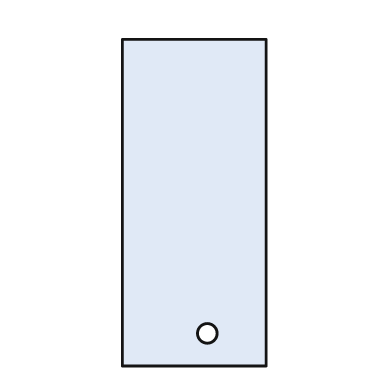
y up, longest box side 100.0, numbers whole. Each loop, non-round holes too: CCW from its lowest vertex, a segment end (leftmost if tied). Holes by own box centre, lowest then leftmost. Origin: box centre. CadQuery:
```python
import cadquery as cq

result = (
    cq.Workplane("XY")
    .moveTo(-22.0, -50.0)
    .lineTo(22.0, -50.0)
    .lineTo(22.0, 50.0)
    .lineTo(-22.0, 50.0)
    .close()
    .moveTo(4.0, -40.0)
    .circle(3.0)
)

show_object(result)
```